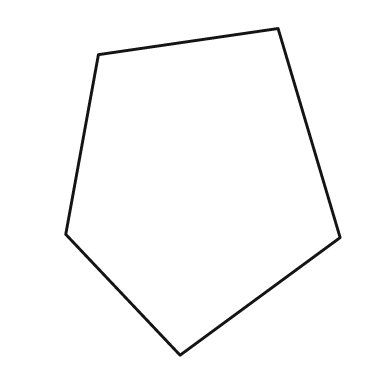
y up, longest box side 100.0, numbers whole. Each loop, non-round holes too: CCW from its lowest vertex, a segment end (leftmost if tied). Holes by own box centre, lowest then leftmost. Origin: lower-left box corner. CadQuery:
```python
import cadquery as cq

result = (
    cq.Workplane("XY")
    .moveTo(35.0, 0.0)
    .lineTo(84.0, 36.0)
    .lineTo(65.0, 100.0)
    .lineTo(10.0, 92.0)
    .lineTo(0.0, 37.0)
    .close()
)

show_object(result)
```